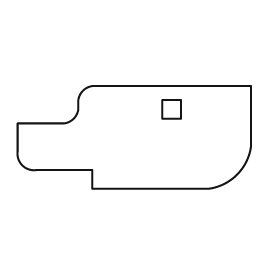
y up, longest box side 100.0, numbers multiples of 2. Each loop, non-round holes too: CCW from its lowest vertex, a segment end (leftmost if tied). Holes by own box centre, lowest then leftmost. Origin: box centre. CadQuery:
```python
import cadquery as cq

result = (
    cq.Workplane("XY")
    .moveTo(-18.0, -22.0)
    .lineTo(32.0, -22.0)
    .threePointArc((44.0, -16.0), (50.0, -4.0))
    .lineTo(50.0, 22.0)
    .lineTo(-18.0, 22.0)
    .threePointArc((-22.0, 20.0), (-24.0, 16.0))
    .lineTo(-24.0, 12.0)
    .threePointArc((-26.0, 8.0), (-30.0, 6.0))
    .lineTo(-50.0, 6.0)
    .lineTo(-50.0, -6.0)
    .threePointArc((-48.0, -12.0), (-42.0, -14.0))
    .lineTo(-18.0, -14.0)
    .close()
    .moveTo(12.0, 8.0)
    .lineTo(20.0, 8.0)
    .lineTo(20.0, 16.0)
    .lineTo(12.0, 16.0)
    .close()
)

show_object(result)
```